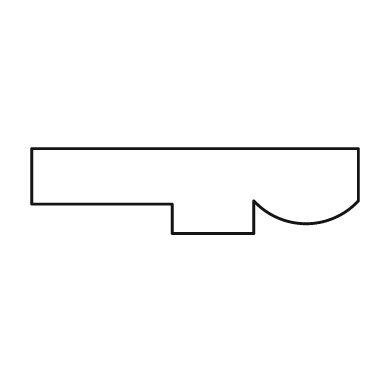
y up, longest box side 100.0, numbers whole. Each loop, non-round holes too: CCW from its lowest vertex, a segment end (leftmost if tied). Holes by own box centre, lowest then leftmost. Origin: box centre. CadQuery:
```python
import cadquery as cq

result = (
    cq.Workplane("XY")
    .moveTo(-7.0, -13.0)
    .lineTo(18.0, -13.0)
    .lineTo(18.0, -3.0)
    .threePointArc((34.0, -10.0), (50.0, -3.0))
    .lineTo(50.0, 13.0)
    .lineTo(-50.0, 13.0)
    .lineTo(-50.0, -4.0)
    .lineTo(-7.0, -4.0)
    .close()
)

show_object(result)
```